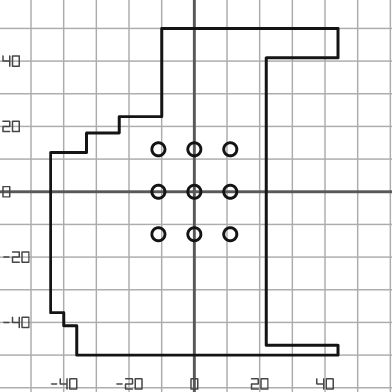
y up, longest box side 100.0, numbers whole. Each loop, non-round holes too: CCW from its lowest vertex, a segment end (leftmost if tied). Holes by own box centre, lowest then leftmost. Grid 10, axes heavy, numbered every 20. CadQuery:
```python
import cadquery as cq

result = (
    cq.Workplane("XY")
    .moveTo(-36.0, -50.0)
    .lineTo(44.0, -50.0)
    .lineTo(44.0, -47.0)
    .lineTo(22.0, -47.0)
    .lineTo(22.0, 41.0)
    .lineTo(44.0, 41.0)
    .lineTo(44.0, 50.0)
    .lineTo(-10.0, 50.0)
    .lineTo(-10.0, 23.0)
    .lineTo(-23.0, 23.0)
    .lineTo(-23.0, 18.0)
    .lineTo(-33.0, 18.0)
    .lineTo(-33.0, 12.0)
    .lineTo(-44.0, 12.0)
    .lineTo(-44.0, -37.0)
    .lineTo(-40.0, -37.0)
    .lineTo(-40.0, -41.0)
    .lineTo(-36.0, -41.0)
    .close()
    .moveTo(-11.0, -13.0)
    .circle(2.0)
    .moveTo(0.0, -13.0)
    .circle(2.0)
    .moveTo(11.0, -13.0)
    .circle(2.0)
    .moveTo(-11.0, 0.0)
    .circle(2.0)
    .moveTo(0.0, 0.0)
    .circle(2.0)
    .moveTo(11.0, 0.0)
    .circle(2.0)
    .moveTo(-11.0, 13.0)
    .circle(2.0)
    .moveTo(0.0, 13.0)
    .circle(2.0)
    .moveTo(11.0, 13.0)
    .circle(2.0)
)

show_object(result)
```